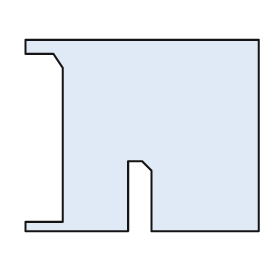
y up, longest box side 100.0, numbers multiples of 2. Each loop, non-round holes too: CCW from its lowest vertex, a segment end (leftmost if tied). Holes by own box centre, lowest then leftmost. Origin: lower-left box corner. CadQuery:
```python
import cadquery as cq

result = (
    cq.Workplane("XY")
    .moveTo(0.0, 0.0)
    .lineTo(44.0, 0.0)
    .lineTo(44.0, 30.0)
    .lineTo(50.0, 30.0)
    .lineTo(54.0, 26.0)
    .lineTo(54.0, 0.0)
    .lineTo(100.0, 0.0)
    .lineTo(100.0, 82.0)
    .lineTo(0.0, 82.0)
    .lineTo(0.0, 76.0)
    .lineTo(12.0, 76.0)
    .lineTo(16.0, 70.0)
    .lineTo(16.0, 4.0)
    .lineTo(0.0, 4.0)
    .close()
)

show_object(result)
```